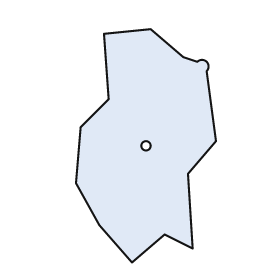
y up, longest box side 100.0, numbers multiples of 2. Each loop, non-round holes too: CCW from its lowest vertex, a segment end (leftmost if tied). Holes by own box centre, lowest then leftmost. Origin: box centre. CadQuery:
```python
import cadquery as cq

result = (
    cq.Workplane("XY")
    .moveTo(-6.0, -50.0)
    .lineTo(8.0, -38.0)
    .lineTo(20.0, -44.0)
    .lineTo(18.0, -12.0)
    .lineTo(30.0, 2.0)
    .lineTo(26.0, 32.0)
    .threePointArc((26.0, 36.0), (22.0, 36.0))
    .lineTo(16.0, 38.0)
    .lineTo(2.0, 50.0)
    .lineTo(-18.0, 48.0)
    .lineTo(-16.0, 20.0)
    .lineTo(-28.0, 8.0)
    .lineTo(-30.0, -16.0)
    .lineTo(-20.0, -34.0)
    .close()
    .moveTo(0.0, 0.0)
    .circle(2.0)
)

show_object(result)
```